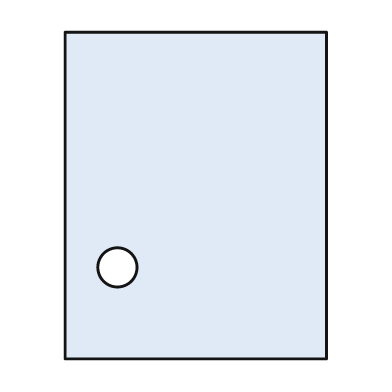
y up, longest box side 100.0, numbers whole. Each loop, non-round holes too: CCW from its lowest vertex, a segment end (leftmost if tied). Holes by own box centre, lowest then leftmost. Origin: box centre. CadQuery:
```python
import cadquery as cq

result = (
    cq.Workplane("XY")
    .moveTo(-40.0, -50.0)
    .lineTo(40.0, -50.0)
    .lineTo(40.0, 50.0)
    .lineTo(-40.0, 50.0)
    .close()
    .moveTo(-24.0, -22.0)
    .circle(6.0)
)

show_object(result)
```